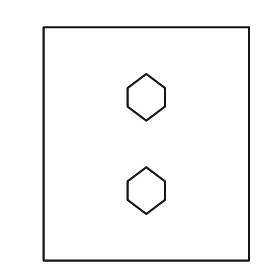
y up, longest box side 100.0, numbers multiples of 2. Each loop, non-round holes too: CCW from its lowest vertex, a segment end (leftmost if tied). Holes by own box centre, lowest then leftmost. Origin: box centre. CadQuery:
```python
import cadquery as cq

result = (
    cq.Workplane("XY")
    .moveTo(-44.0, -50.0)
    .lineTo(44.0, -50.0)
    .lineTo(44.0, 50.0)
    .lineTo(-44.0, 50.0)
    .close()
    .moveTo(0.0, -30.0)
    .lineTo(8.0, -24.0)
    .lineTo(8.0, -16.0)
    .lineTo(0.0, -10.0)
    .lineTo(-8.0, -16.0)
    .lineTo(-8.0, -24.0)
    .close()
    .moveTo(0.0, 10.0)
    .lineTo(8.0, 16.0)
    .lineTo(8.0, 24.0)
    .lineTo(0.0, 30.0)
    .lineTo(-8.0, 24.0)
    .lineTo(-8.0, 16.0)
    .close()
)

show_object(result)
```